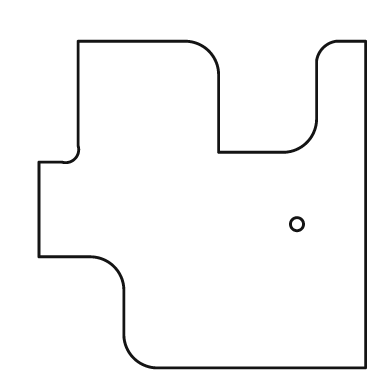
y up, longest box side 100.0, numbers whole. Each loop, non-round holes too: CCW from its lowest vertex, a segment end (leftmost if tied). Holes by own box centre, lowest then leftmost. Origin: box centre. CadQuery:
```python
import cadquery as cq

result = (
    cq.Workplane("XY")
    .moveTo(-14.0, -50.0)
    .lineTo(50.0, -50.0)
    .lineTo(50.0, 50.0)
    .lineTo(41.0, 50.0)
    .threePointArc((37.0, 48.0), (35.0, 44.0))
    .lineTo(35.0, 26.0)
    .threePointArc((32.0, 19.0), (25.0, 16.0))
    .lineTo(5.0, 16.0)
    .lineTo(5.0, 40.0)
    .threePointArc((2.0, 47.0), (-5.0, 50.0))
    .lineTo(-38.0, 50.0)
    .lineTo(-38.0, 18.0)
    .threePointArc((-39.0, 14.0), (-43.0, 13.0))
    .lineTo(-50.0, 13.0)
    .lineTo(-50.0, -16.0)
    .lineTo(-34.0, -16.0)
    .threePointArc((-27.0, -19.0), (-24.0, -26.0))
    .lineTo(-24.0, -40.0)
    .threePointArc((-21.0, -47.0), (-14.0, -50.0))
    .close()
    .moveTo(29.0, -6.0)
    .circle(2.0)
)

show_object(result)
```